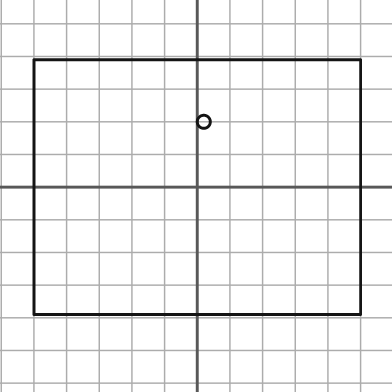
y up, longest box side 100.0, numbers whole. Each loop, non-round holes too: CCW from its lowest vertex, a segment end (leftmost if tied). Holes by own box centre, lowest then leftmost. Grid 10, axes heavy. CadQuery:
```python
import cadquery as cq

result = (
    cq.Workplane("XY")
    .moveTo(-50.0, -39.0)
    .lineTo(50.0, -39.0)
    .lineTo(50.0, 39.0)
    .lineTo(-50.0, 39.0)
    .close()
    .moveTo(2.0, 20.0)
    .circle(2.0)
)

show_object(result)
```